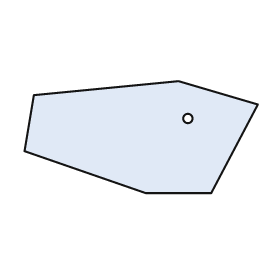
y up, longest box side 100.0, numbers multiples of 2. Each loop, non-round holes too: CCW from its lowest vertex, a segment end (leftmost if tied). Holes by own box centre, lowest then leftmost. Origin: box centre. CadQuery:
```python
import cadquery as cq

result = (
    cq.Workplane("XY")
    .moveTo(2.0, -24.0)
    .lineTo(30.0, -24.0)
    .lineTo(50.0, 14.0)
    .lineTo(16.0, 24.0)
    .lineTo(-46.0, 18.0)
    .lineTo(-50.0, -6.0)
    .close()
    .moveTo(20.0, 8.0)
    .circle(2.0)
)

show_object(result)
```